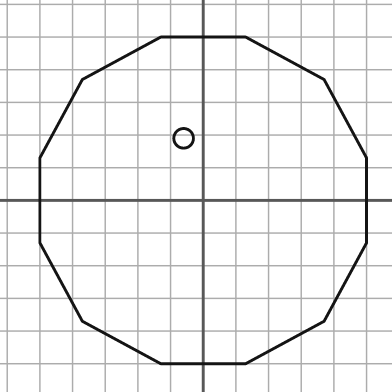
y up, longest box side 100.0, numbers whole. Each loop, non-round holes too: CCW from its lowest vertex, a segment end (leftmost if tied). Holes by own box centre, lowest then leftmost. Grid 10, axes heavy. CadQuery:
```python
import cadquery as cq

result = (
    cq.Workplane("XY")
    .moveTo(-13.0, -50.0)
    .lineTo(13.0, -50.0)
    .lineTo(37.0, -37.0)
    .lineTo(50.0, -13.0)
    .lineTo(50.0, 13.0)
    .lineTo(37.0, 37.0)
    .lineTo(13.0, 50.0)
    .lineTo(-13.0, 50.0)
    .lineTo(-37.0, 37.0)
    .lineTo(-50.0, 13.0)
    .lineTo(-50.0, -13.0)
    .lineTo(-37.0, -37.0)
    .close()
    .moveTo(-6.0, 19.0)
    .circle(3.0)
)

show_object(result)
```